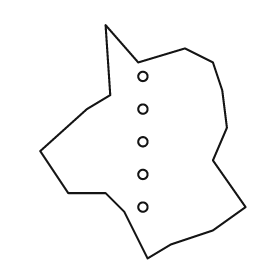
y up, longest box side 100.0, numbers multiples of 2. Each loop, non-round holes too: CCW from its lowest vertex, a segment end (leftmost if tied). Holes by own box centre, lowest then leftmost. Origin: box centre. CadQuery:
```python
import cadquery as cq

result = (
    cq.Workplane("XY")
    .moveTo(2.0, -50.0)
    .lineTo(12.0, -44.0)
    .lineTo(30.0, -38.0)
    .lineTo(44.0, -28.0)
    .lineTo(30.0, -8.0)
    .lineTo(36.0, 6.0)
    .lineTo(34.0, 22.0)
    .lineTo(30.0, 34.0)
    .lineTo(18.0, 40.0)
    .lineTo(-2.0, 34.0)
    .lineTo(-16.0, 50.0)
    .lineTo(-14.0, 20.0)
    .lineTo(-24.0, 14.0)
    .lineTo(-44.0, -4.0)
    .lineTo(-32.0, -22.0)
    .lineTo(-16.0, -22.0)
    .lineTo(-8.0, -30.0)
    .close()
    .moveTo(0.0, -28.0)
    .circle(2.0)
    .moveTo(0.0, -14.0)
    .circle(2.0)
    .moveTo(0.0, 0.0)
    .circle(2.0)
    .moveTo(0.0, 14.0)
    .circle(2.0)
    .moveTo(0.0, 28.0)
    .circle(2.0)
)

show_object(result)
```